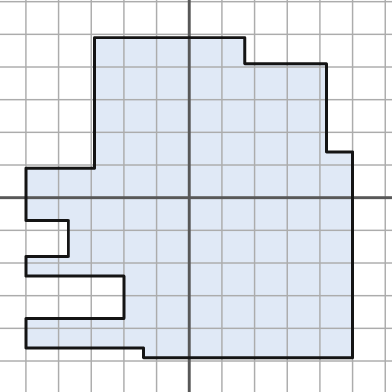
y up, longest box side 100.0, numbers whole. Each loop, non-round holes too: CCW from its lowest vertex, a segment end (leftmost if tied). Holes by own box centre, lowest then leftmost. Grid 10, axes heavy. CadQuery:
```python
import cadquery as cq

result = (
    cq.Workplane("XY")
    .moveTo(-14.0, -49.0)
    .lineTo(50.0, -49.0)
    .lineTo(50.0, 14.0)
    .lineTo(42.0, 14.0)
    .lineTo(42.0, 41.0)
    .lineTo(17.0, 41.0)
    .lineTo(17.0, 49.0)
    .lineTo(-29.0, 49.0)
    .lineTo(-29.0, 9.0)
    .lineTo(-50.0, 9.0)
    .lineTo(-50.0, -7.0)
    .lineTo(-37.0, -7.0)
    .lineTo(-37.0, -18.0)
    .lineTo(-50.0, -18.0)
    .lineTo(-50.0, -24.0)
    .lineTo(-20.0, -24.0)
    .lineTo(-20.0, -37.0)
    .lineTo(-50.0, -37.0)
    .lineTo(-50.0, -46.0)
    .lineTo(-14.0, -46.0)
    .close()
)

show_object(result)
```